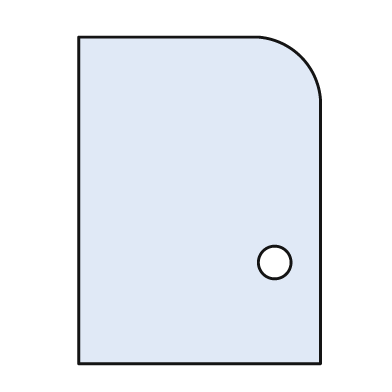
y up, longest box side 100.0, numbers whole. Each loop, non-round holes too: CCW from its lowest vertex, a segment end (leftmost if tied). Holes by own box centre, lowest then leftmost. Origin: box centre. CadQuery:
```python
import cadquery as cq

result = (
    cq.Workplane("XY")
    .moveTo(-37.0, -50.0)
    .lineTo(37.0, -50.0)
    .lineTo(37.0, 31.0)
    .threePointArc((31.0, 44.0), (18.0, 50.0))
    .lineTo(-37.0, 50.0)
    .close()
    .moveTo(23.0, -19.0)
    .circle(5.0)
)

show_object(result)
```